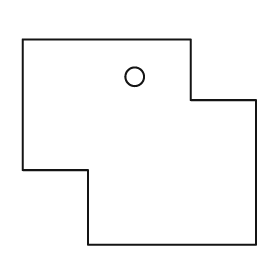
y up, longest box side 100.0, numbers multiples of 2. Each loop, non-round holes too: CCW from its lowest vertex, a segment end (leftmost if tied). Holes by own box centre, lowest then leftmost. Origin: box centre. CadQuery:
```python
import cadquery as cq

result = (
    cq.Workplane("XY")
    .moveTo(-22.0, -44.0)
    .lineTo(50.0, -44.0)
    .lineTo(50.0, 18.0)
    .lineTo(22.0, 18.0)
    .lineTo(22.0, 44.0)
    .lineTo(-50.0, 44.0)
    .lineTo(-50.0, -12.0)
    .lineTo(-22.0, -12.0)
    .close()
    .moveTo(-2.0, 28.0)
    .circle(4.0)
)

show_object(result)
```